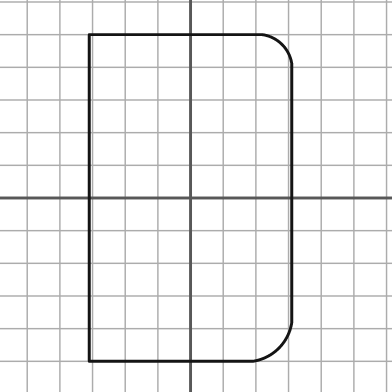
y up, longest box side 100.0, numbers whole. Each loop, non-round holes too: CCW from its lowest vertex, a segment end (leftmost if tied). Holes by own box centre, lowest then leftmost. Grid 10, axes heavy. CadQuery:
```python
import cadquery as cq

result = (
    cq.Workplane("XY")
    .moveTo(-31.0, -50.0)
    .lineTo(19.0, -50.0)
    .threePointArc((27.0, -46.0), (31.0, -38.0))
    .lineTo(31.0, 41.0)
    .threePointArc((28.0, 47.0), (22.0, 50.0))
    .lineTo(-31.0, 50.0)
    .close()
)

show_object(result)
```